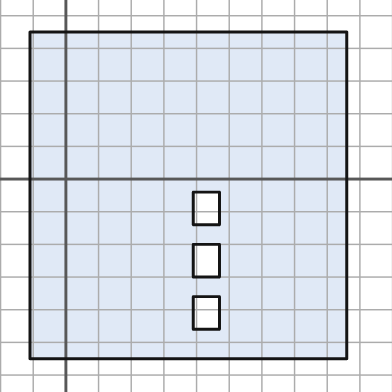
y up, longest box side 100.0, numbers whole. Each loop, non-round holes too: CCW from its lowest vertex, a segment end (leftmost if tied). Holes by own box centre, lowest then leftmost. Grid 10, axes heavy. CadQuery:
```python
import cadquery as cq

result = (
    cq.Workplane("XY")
    .moveTo(-11.0, -55.0)
    .lineTo(86.0, -55.0)
    .lineTo(86.0, 45.0)
    .lineTo(-11.0, 45.0)
    .close()
    .moveTo(39.0, -46.0)
    .lineTo(47.0, -46.0)
    .lineTo(47.0, -36.0)
    .lineTo(39.0, -36.0)
    .close()
    .moveTo(39.0, -30.0)
    .lineTo(47.0, -30.0)
    .lineTo(47.0, -20.0)
    .lineTo(39.0, -20.0)
    .close()
    .moveTo(39.0, -14.0)
    .lineTo(47.0, -14.0)
    .lineTo(47.0, -4.0)
    .lineTo(39.0, -4.0)
    .close()
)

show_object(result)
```